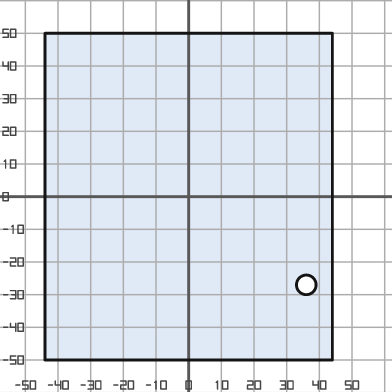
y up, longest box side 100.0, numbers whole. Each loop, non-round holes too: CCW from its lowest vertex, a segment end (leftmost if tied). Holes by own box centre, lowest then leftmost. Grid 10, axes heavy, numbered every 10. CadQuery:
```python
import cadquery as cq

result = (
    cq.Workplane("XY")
    .moveTo(-44.0, -50.0)
    .lineTo(44.0, -50.0)
    .lineTo(44.0, 50.0)
    .lineTo(-44.0, 50.0)
    .close()
    .moveTo(36.0, -27.0)
    .circle(3.0)
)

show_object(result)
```